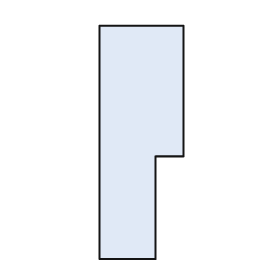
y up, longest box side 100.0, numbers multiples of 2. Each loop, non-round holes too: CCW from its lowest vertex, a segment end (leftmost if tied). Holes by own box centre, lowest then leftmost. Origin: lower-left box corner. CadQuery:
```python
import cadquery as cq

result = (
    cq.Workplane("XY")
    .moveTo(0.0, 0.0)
    .lineTo(24.0, 0.0)
    .lineTo(24.0, 44.0)
    .lineTo(36.0, 44.0)
    .lineTo(36.0, 100.0)
    .lineTo(0.0, 100.0)
    .close()
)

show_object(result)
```